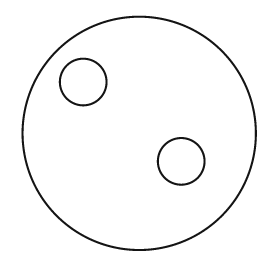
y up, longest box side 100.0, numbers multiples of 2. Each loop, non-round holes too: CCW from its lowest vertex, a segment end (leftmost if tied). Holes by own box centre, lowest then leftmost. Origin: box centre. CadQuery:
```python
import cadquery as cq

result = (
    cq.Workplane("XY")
    .moveTo(0.0, 0.0)
    .circle(50.0)
    .moveTo(18.0, -12.0)
    .circle(10.0)
    .moveTo(-24.0, 22.0)
    .circle(10.0)
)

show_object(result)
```